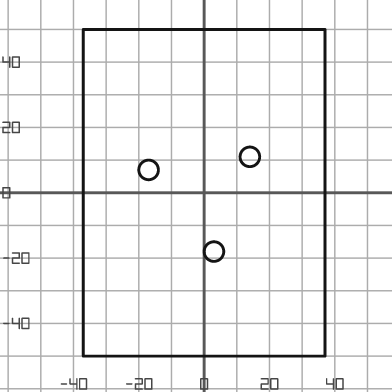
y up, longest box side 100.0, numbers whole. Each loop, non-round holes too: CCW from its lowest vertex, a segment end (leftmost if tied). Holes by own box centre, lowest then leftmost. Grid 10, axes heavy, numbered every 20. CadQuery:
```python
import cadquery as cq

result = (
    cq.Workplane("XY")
    .moveTo(-37.0, -50.0)
    .lineTo(37.0, -50.0)
    .lineTo(37.0, 50.0)
    .lineTo(-37.0, 50.0)
    .close()
    .moveTo(3.0, -18.0)
    .circle(3.0)
    .moveTo(-17.0, 7.0)
    .circle(3.0)
    .moveTo(14.0, 11.0)
    .circle(3.0)
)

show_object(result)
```